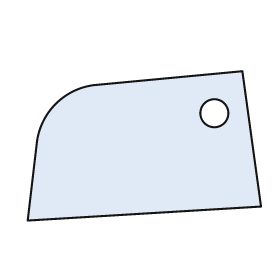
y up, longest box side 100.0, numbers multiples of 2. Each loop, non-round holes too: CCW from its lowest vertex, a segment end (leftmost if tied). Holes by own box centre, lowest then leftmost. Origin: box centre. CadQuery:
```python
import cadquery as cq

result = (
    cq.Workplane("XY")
    .moveTo(-50.0, -32.0)
    .lineTo(50.0, -26.0)
    .lineTo(42.0, 32.0)
    .lineTo(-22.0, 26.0)
    .threePointArc((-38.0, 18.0), (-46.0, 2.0))
    .close()
    .moveTo(30.0, 14.0)
    .circle(6.0)
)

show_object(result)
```